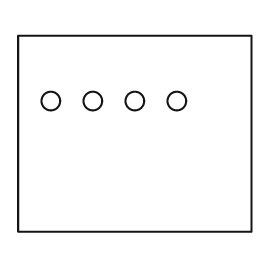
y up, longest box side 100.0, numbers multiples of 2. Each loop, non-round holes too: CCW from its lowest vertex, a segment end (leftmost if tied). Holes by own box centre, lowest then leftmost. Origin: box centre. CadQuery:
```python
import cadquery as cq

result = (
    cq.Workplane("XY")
    .moveTo(-50.0, -42.0)
    .lineTo(50.0, -42.0)
    .lineTo(50.0, 42.0)
    .lineTo(-50.0, 42.0)
    .close()
    .moveTo(-36.0, 14.0)
    .circle(4.0)
    .moveTo(-18.0, 14.0)
    .circle(4.0)
    .moveTo(0.0, 14.0)
    .circle(4.0)
    .moveTo(18.0, 14.0)
    .circle(4.0)
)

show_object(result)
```